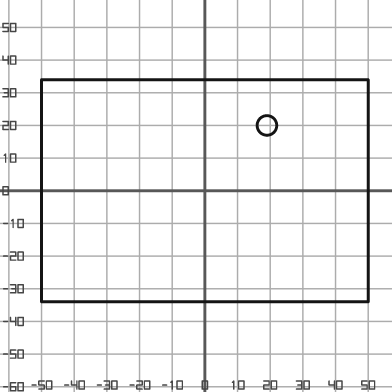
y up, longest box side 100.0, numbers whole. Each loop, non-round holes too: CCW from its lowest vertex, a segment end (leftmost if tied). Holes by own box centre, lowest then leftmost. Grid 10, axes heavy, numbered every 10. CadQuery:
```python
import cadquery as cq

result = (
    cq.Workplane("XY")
    .moveTo(-50.0, -34.0)
    .lineTo(50.0, -34.0)
    .lineTo(50.0, 34.0)
    .lineTo(-50.0, 34.0)
    .close()
    .moveTo(19.0, 20.0)
    .circle(3.0)
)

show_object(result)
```